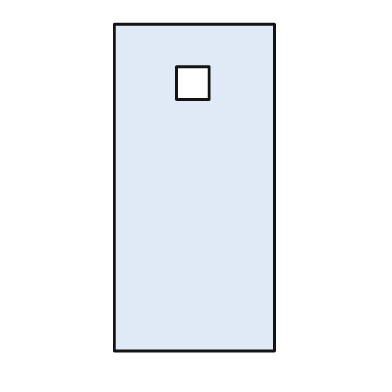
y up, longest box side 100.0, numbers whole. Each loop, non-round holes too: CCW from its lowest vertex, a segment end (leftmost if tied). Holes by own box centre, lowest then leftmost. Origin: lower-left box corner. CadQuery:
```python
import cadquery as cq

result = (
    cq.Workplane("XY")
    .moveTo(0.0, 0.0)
    .lineTo(49.0, 0.0)
    .lineTo(49.0, 100.0)
    .lineTo(0.0, 100.0)
    .close()
    .moveTo(19.0, 77.0)
    .lineTo(29.0, 77.0)
    .lineTo(29.0, 87.0)
    .lineTo(19.0, 87.0)
    .close()
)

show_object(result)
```